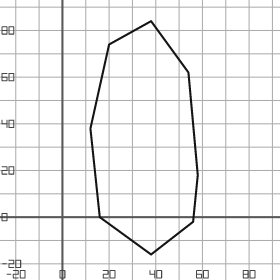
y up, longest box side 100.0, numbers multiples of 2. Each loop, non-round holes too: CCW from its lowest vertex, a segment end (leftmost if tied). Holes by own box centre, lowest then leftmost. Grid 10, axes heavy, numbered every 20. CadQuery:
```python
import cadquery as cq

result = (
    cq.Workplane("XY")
    .moveTo(38.0, -16.0)
    .lineTo(56.0, -2.0)
    .lineTo(58.0, 18.0)
    .lineTo(54.0, 62.0)
    .lineTo(38.0, 84.0)
    .lineTo(20.0, 74.0)
    .lineTo(12.0, 38.0)
    .lineTo(16.0, 0.0)
    .close()
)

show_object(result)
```